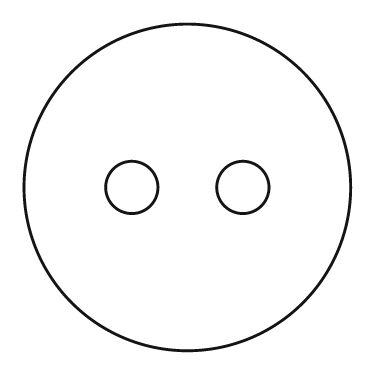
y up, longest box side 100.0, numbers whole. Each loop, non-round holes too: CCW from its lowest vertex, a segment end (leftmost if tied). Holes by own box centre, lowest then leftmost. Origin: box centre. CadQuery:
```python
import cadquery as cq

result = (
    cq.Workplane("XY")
    .moveTo(0.0, 0.0)
    .circle(50.0)
    .moveTo(-17.0, 0.0)
    .circle(8.0)
    .moveTo(17.0, 0.0)
    .circle(8.0)
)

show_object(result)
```